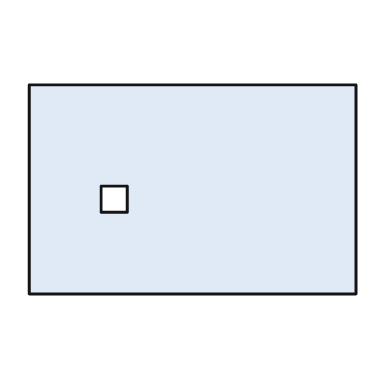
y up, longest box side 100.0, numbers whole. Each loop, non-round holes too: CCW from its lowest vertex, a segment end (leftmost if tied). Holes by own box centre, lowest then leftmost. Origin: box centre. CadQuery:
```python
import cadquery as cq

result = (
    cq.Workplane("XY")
    .moveTo(-50.0, -32.0)
    .lineTo(50.0, -32.0)
    .lineTo(50.0, 32.0)
    .lineTo(-50.0, 32.0)
    .close()
    .moveTo(-28.0, -7.0)
    .lineTo(-20.0, -7.0)
    .lineTo(-20.0, 1.0)
    .lineTo(-28.0, 1.0)
    .close()
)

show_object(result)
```